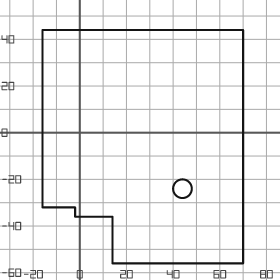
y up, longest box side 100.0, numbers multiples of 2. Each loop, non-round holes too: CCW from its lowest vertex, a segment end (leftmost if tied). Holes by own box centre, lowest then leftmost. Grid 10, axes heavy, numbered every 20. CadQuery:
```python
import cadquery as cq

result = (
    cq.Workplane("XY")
    .moveTo(14.0, -56.0)
    .lineTo(70.0, -56.0)
    .lineTo(70.0, 44.0)
    .lineTo(-16.0, 44.0)
    .lineTo(-16.0, -32.0)
    .lineTo(-2.0, -32.0)
    .lineTo(-2.0, -36.0)
    .lineTo(14.0, -36.0)
    .close()
    .moveTo(44.0, -24.0)
    .circle(4.0)
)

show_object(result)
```